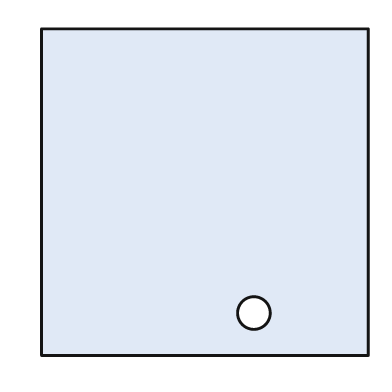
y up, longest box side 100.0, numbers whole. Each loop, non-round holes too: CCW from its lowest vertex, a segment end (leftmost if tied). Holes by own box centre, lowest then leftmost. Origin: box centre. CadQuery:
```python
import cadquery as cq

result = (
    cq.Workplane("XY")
    .moveTo(-50.0, -50.0)
    .lineTo(50.0, -50.0)
    .lineTo(50.0, 50.0)
    .lineTo(-50.0, 50.0)
    .close()
    .moveTo(15.0, -37.0)
    .circle(5.0)
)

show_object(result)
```